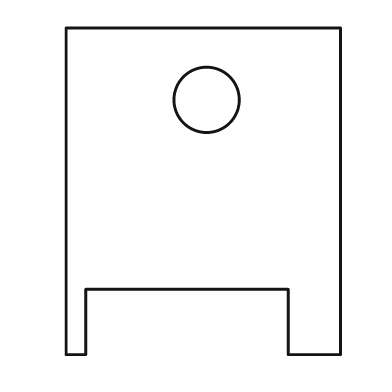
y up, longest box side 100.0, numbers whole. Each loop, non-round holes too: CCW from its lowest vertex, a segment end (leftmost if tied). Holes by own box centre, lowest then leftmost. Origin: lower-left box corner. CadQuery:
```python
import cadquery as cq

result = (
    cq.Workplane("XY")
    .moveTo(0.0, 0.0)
    .lineTo(6.0, 0.0)
    .lineTo(6.0, 20.0)
    .lineTo(68.0, 20.0)
    .lineTo(68.0, 0.0)
    .lineTo(84.0, 0.0)
    .lineTo(84.0, 100.0)
    .lineTo(0.0, 100.0)
    .close()
    .moveTo(43.0, 78.0)
    .circle(10.0)
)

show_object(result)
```